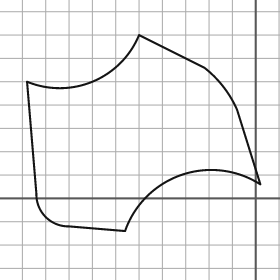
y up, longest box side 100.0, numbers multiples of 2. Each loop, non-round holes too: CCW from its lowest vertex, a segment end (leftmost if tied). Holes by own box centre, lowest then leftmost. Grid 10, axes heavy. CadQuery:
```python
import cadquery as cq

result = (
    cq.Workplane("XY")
    .moveTo(-56.0, -14.0)
    .threePointArc((-32.0, 10.0), (2.0, 6.0))
    .lineTo(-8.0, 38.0)
    .threePointArc((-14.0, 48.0), (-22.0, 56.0))
    .lineTo(-50.0, 70.0)
    .threePointArc((-70.0, 50.0), (-98.0, 50.0))
    .lineTo(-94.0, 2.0)
    .threePointArc((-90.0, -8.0), (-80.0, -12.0))
    .close()
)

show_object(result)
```